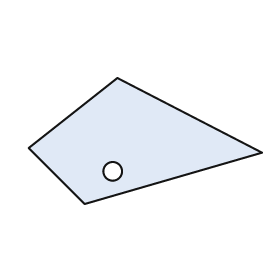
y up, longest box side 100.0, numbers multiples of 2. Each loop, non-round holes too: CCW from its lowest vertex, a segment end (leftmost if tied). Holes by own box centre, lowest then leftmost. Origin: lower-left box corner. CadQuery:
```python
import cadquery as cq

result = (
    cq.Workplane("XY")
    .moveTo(24.0, 0.0)
    .lineTo(100.0, 22.0)
    .lineTo(38.0, 54.0)
    .lineTo(0.0, 24.0)
    .close()
    .moveTo(36.0, 14.0)
    .circle(4.0)
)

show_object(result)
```